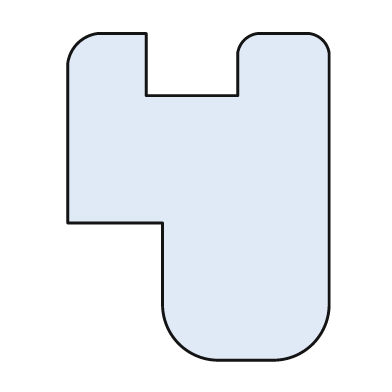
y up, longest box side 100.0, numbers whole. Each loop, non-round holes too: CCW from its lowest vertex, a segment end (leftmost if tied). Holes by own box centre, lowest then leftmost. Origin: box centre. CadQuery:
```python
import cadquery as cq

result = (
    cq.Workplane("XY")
    .moveTo(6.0, -50.0)
    .lineTo(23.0, -50.0)
    .threePointArc((35.0, -45.0), (40.0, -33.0))
    .lineTo(40.0, 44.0)
    .threePointArc((38.0, 48.0), (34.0, 50.0))
    .lineTo(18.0, 50.0)
    .threePointArc((14.0, 48.0), (12.0, 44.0))
    .lineTo(12.0, 31.0)
    .lineTo(-16.0, 31.0)
    .lineTo(-16.0, 50.0)
    .lineTo(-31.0, 50.0)
    .threePointArc((-37.0, 47.0), (-40.0, 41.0))
    .lineTo(-40.0, -8.0)
    .lineTo(-11.0, -8.0)
    .lineTo(-11.0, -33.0)
    .threePointArc((-6.0, -45.0), (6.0, -50.0))
    .close()
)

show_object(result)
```